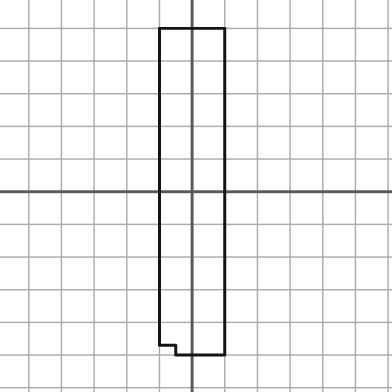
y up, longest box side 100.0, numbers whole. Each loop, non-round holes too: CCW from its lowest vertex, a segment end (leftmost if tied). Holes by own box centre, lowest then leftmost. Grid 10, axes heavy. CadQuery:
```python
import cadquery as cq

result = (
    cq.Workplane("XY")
    .moveTo(-5.0, -50.0)
    .lineTo(10.0, -50.0)
    .lineTo(10.0, 50.0)
    .lineTo(-10.0, 50.0)
    .lineTo(-10.0, -47.0)
    .lineTo(-5.0, -47.0)
    .close()
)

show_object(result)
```